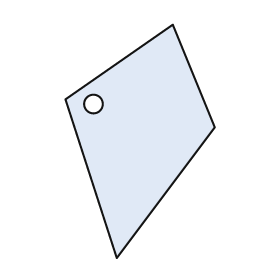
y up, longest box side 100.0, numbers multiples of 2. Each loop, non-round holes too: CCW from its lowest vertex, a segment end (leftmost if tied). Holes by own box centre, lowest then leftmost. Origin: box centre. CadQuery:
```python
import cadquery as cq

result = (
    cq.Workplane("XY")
    .moveTo(-10.0, -50.0)
    .lineTo(32.0, 6.0)
    .lineTo(14.0, 50.0)
    .lineTo(-32.0, 18.0)
    .close()
    .moveTo(-20.0, 16.0)
    .circle(4.0)
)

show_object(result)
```